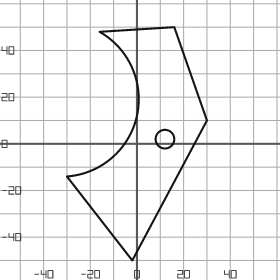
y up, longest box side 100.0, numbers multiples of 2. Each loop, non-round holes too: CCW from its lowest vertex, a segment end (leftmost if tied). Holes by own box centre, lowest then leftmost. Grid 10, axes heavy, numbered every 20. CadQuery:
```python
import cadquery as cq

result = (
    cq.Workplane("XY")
    .moveTo(-2.0, -50.0)
    .lineTo(30.0, 10.0)
    .lineTo(16.0, 50.0)
    .lineTo(-16.0, 48.0)
    .threePointArc((0.0, 12.0), (-30.0, -14.0))
    .close()
    .moveTo(12.0, 2.0)
    .circle(4.0)
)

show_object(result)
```